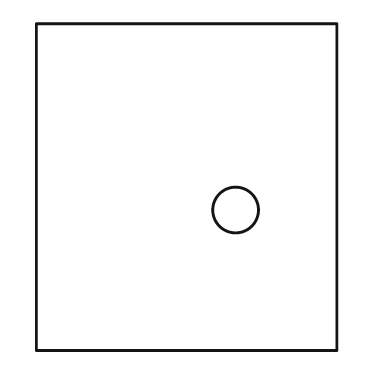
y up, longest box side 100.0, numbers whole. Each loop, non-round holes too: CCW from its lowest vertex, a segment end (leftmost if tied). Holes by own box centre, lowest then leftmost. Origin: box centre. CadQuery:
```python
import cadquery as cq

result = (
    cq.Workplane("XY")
    .moveTo(-46.0, -50.0)
    .lineTo(46.0, -50.0)
    .lineTo(46.0, 50.0)
    .lineTo(-46.0, 50.0)
    .close()
    .moveTo(15.0, -7.0)
    .circle(7.0)
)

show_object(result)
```